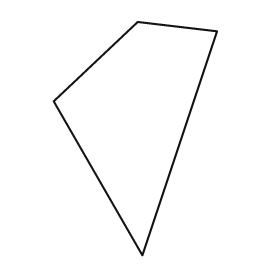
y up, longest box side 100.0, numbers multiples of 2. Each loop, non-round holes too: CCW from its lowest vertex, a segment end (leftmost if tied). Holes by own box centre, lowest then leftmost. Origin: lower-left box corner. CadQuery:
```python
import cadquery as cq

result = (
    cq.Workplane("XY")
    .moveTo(38.0, 0.0)
    .lineTo(70.0, 96.0)
    .lineTo(36.0, 100.0)
    .lineTo(0.0, 66.0)
    .close()
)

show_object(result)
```